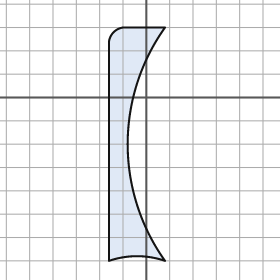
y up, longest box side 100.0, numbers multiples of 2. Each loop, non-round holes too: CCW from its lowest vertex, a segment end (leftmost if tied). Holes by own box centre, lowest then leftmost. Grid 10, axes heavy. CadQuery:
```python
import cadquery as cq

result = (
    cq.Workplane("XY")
    .moveTo(-16.0, -70.0)
    .threePointArc((-4.0, -68.0), (8.0, -70.0))
    .threePointArc((-8.0, -20.0), (8.0, 30.0))
    .lineTo(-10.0, 30.0)
    .threePointArc((-14.0, 28.0), (-16.0, 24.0))
    .close()
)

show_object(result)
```